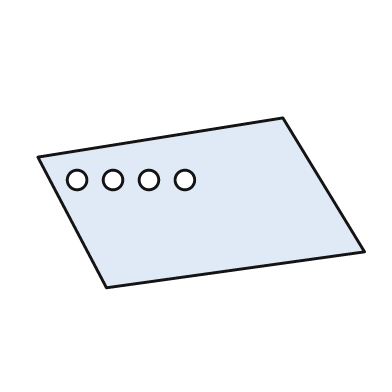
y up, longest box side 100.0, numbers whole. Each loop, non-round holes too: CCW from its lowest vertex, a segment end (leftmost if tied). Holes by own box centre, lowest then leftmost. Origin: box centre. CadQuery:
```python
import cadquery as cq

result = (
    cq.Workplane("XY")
    .moveTo(-29.0, -26.0)
    .lineTo(50.0, -15.0)
    .lineTo(25.0, 26.0)
    .lineTo(-50.0, 14.0)
    .close()
    .moveTo(-38.0, 7.0)
    .circle(3.0)
    .moveTo(-27.0, 7.0)
    .circle(3.0)
    .moveTo(-16.0, 7.0)
    .circle(3.0)
    .moveTo(-5.0, 7.0)
    .circle(3.0)
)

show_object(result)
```